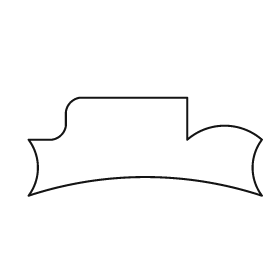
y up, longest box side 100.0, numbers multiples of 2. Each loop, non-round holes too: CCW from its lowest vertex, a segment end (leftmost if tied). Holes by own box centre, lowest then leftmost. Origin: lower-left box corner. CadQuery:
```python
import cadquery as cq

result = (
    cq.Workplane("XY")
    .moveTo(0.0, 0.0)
    .threePointArc((50.0, 8.0), (100.0, 0.0))
    .threePointArc((96.0, 12.0), (100.0, 24.0))
    .threePointArc((84.0, 30.0), (68.0, 24.0))
    .lineTo(68.0, 42.0)
    .lineTo(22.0, 42.0)
    .threePointArc((18.0, 40.0), (16.0, 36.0))
    .lineTo(16.0, 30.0)
    .threePointArc((14.0, 26.0), (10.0, 24.0))
    .lineTo(0.0, 24.0)
    .threePointArc((4.0, 12.0), (0.0, 0.0))
    .close()
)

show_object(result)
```